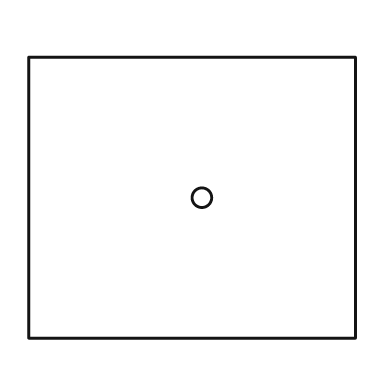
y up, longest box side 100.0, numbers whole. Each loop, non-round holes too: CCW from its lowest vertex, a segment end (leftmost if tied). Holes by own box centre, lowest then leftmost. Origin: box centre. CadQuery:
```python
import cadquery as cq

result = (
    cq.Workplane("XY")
    .moveTo(-50.0, -43.0)
    .lineTo(50.0, -43.0)
    .lineTo(50.0, 43.0)
    .lineTo(-50.0, 43.0)
    .close()
    .moveTo(3.0, 0.0)
    .circle(3.0)
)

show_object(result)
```